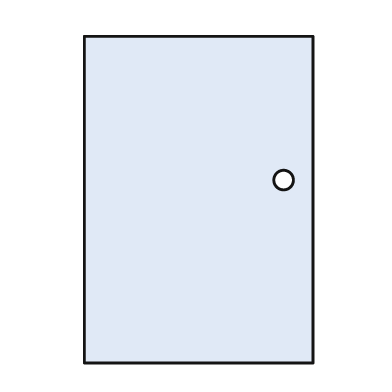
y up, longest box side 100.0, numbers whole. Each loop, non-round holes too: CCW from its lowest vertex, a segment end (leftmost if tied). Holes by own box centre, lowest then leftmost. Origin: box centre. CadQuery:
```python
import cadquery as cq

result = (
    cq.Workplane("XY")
    .moveTo(-35.0, -50.0)
    .lineTo(35.0, -50.0)
    .lineTo(35.0, 50.0)
    .lineTo(-35.0, 50.0)
    .close()
    .moveTo(26.0, 6.0)
    .circle(3.0)
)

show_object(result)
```